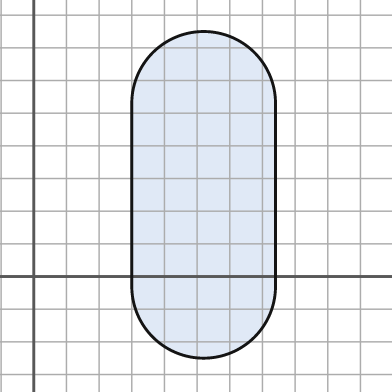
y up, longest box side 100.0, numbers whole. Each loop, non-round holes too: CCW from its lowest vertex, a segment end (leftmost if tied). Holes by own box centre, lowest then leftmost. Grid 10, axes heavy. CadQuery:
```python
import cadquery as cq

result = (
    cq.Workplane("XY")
    .moveTo(30.0, -3.0)
    .threePointArc((52.0, -25.0), (74.0, -3.0))
    .lineTo(74.0, 53.0)
    .threePointArc((52.0, 75.0), (30.0, 53.0))
    .close()
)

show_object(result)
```